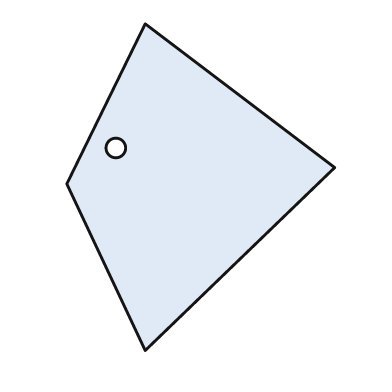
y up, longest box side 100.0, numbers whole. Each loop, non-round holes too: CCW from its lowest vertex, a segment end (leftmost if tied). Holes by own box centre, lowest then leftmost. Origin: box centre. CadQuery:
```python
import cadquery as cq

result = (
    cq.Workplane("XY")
    .moveTo(-17.0, -50.0)
    .lineTo(41.0, 6.0)
    .lineTo(-17.0, 50.0)
    .lineTo(-41.0, 1.0)
    .close()
    .moveTo(-26.0, 12.0)
    .circle(3.0)
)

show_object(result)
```